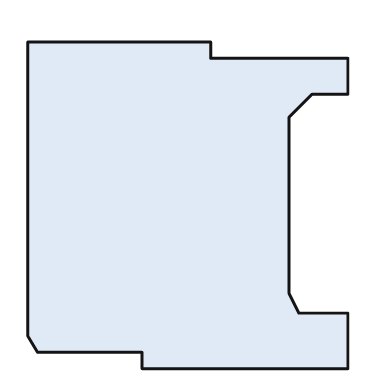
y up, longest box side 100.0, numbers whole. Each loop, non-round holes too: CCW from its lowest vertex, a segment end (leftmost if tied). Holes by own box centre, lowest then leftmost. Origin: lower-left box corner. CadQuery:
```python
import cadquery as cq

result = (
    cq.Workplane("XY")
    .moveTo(35.0, 0.0)
    .lineTo(98.0, 0.0)
    .lineTo(98.0, 17.0)
    .lineTo(83.0, 17.0)
    .lineTo(80.0, 23.0)
    .lineTo(80.0, 77.0)
    .lineTo(87.0, 84.0)
    .lineTo(98.0, 84.0)
    .lineTo(98.0, 95.0)
    .lineTo(56.0, 95.0)
    .lineTo(56.0, 100.0)
    .lineTo(0.0, 100.0)
    .lineTo(0.0, 10.0)
    .lineTo(3.0, 5.0)
    .lineTo(35.0, 5.0)
    .close()
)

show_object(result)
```